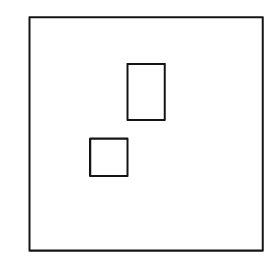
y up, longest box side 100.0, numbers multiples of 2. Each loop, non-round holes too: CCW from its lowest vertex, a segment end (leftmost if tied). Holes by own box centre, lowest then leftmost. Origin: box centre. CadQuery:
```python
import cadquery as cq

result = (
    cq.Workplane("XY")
    .moveTo(-50.0, -50.0)
    .lineTo(50.0, -50.0)
    .lineTo(50.0, 50.0)
    .lineTo(-50.0, 50.0)
    .close()
    .moveTo(-24.0, -18.0)
    .lineTo(-8.0, -18.0)
    .lineTo(-8.0, -2.0)
    .lineTo(-24.0, -2.0)
    .close()
    .moveTo(-8.0, 6.0)
    .lineTo(8.0, 6.0)
    .lineTo(8.0, 30.0)
    .lineTo(-8.0, 30.0)
    .close()
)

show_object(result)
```